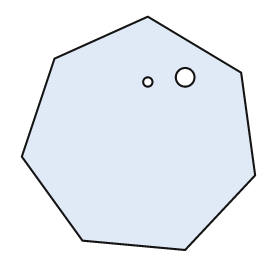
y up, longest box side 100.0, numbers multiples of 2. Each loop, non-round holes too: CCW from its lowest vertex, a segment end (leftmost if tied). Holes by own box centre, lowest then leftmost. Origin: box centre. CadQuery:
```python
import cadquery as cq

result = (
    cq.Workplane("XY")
    .moveTo(20.0, -50.0)
    .lineTo(50.0, -18.0)
    .lineTo(44.0, 26.0)
    .lineTo(4.0, 50.0)
    .lineTo(-36.0, 32.0)
    .lineTo(-50.0, -10.0)
    .lineTo(-24.0, -46.0)
    .close()
    .moveTo(4.0, 22.0)
    .circle(2.0)
    .moveTo(20.0, 24.0)
    .circle(4.0)
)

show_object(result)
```